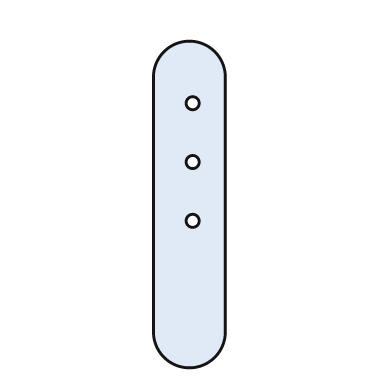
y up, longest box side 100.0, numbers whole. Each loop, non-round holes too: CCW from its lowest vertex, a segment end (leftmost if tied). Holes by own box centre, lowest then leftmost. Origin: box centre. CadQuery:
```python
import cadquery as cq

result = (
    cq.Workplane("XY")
    .moveTo(-11.0, -39.0)
    .threePointArc((0.0, -50.0), (11.0, -39.0))
    .lineTo(11.0, 39.0)
    .threePointArc((0.0, 50.0), (-11.0, 39.0))
    .close()
    .moveTo(1.0, -5.0)
    .circle(2.0)
    .moveTo(1.0, 13.0)
    .circle(2.0)
    .moveTo(1.0, 31.0)
    .circle(2.0)
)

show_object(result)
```